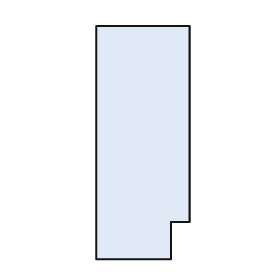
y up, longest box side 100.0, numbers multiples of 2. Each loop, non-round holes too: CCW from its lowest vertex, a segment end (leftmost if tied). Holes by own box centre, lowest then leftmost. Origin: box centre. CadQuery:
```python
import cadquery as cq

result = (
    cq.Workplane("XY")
    .moveTo(-20.0, -50.0)
    .lineTo(12.0, -50.0)
    .lineTo(12.0, -34.0)
    .lineTo(20.0, -34.0)
    .lineTo(20.0, 50.0)
    .lineTo(-20.0, 50.0)
    .close()
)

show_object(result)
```